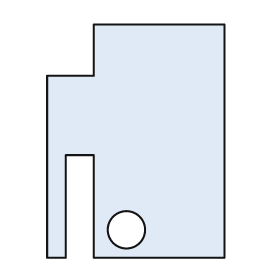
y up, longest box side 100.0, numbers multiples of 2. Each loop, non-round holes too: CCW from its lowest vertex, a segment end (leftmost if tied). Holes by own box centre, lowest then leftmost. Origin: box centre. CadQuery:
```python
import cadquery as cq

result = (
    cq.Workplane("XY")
    .moveTo(-38.0, -50.0)
    .lineTo(-30.0, -50.0)
    .lineTo(-30.0, -6.0)
    .lineTo(-18.0, -6.0)
    .lineTo(-18.0, -50.0)
    .lineTo(38.0, -50.0)
    .lineTo(38.0, 50.0)
    .lineTo(-18.0, 50.0)
    .lineTo(-18.0, 28.0)
    .lineTo(-38.0, 28.0)
    .close()
    .moveTo(-4.0, -38.0)
    .circle(8.0)
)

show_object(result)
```